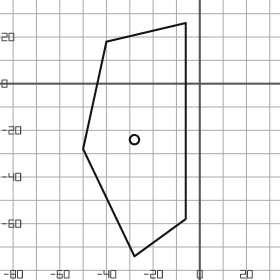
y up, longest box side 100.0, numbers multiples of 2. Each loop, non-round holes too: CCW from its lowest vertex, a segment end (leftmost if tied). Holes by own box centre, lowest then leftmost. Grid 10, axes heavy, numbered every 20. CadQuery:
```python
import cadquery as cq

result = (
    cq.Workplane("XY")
    .moveTo(-28.0, -74.0)
    .lineTo(-6.0, -58.0)
    .lineTo(-6.0, 26.0)
    .lineTo(-40.0, 18.0)
    .lineTo(-50.0, -28.0)
    .close()
    .moveTo(-28.0, -24.0)
    .circle(2.0)
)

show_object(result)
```